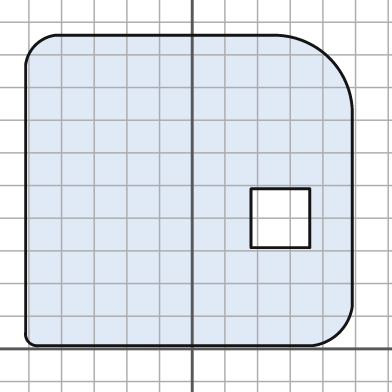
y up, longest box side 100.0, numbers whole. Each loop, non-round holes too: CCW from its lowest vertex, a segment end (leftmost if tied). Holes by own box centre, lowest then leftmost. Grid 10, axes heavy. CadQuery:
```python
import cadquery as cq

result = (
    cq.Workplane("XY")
    .moveTo(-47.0, 1.0)
    .lineTo(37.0, 1.0)
    .threePointArc((45.0, 5.0), (49.0, 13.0))
    .lineTo(49.0, 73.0)
    .threePointArc((42.0, 89.0), (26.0, 96.0))
    .lineTo(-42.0, 96.0)
    .threePointArc((-48.0, 93.0), (-51.0, 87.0))
    .lineTo(-51.0, 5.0)
    .threePointArc((-50.0, 2.0), (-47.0, 1.0))
    .close()
    .moveTo(18.0, 31.0)
    .lineTo(36.0, 31.0)
    .lineTo(36.0, 49.0)
    .lineTo(18.0, 49.0)
    .close()
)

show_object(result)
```